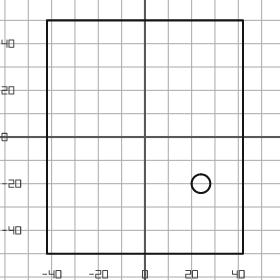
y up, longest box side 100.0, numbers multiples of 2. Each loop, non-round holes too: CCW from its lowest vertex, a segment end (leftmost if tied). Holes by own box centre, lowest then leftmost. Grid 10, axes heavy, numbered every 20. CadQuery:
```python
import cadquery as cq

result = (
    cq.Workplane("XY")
    .moveTo(-42.0, -50.0)
    .lineTo(42.0, -50.0)
    .lineTo(42.0, 50.0)
    .lineTo(-42.0, 50.0)
    .close()
    .moveTo(24.0, -20.0)
    .circle(4.0)
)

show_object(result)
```